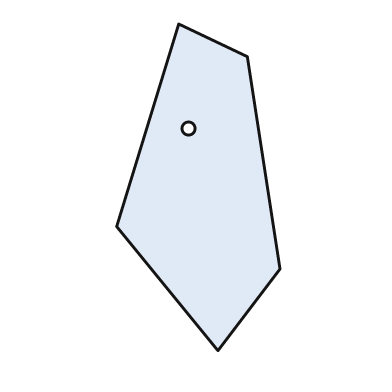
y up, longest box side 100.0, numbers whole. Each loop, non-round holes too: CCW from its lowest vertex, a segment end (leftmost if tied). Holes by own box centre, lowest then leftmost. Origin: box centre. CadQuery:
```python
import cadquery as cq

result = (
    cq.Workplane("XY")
    .moveTo(6.0, -50.0)
    .lineTo(25.0, -25.0)
    .lineTo(15.0, 40.0)
    .lineTo(-6.0, 50.0)
    .lineTo(-25.0, -12.0)
    .close()
    .moveTo(-3.0, 18.0)
    .circle(2.0)
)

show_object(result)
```